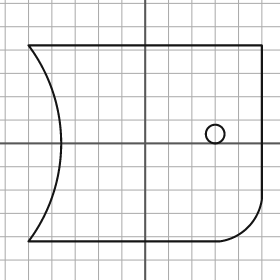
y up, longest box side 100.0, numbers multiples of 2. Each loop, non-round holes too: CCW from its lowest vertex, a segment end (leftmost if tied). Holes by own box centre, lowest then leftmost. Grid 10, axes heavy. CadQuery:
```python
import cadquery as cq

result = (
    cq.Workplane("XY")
    .moveTo(-50.0, -42.0)
    .lineTo(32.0, -42.0)
    .threePointArc((44.0, -36.0), (50.0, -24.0))
    .lineTo(50.0, 42.0)
    .lineTo(-50.0, 42.0)
    .threePointArc((-36.0, 0.0), (-50.0, -42.0))
    .close()
    .moveTo(30.0, 4.0)
    .circle(4.0)
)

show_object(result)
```